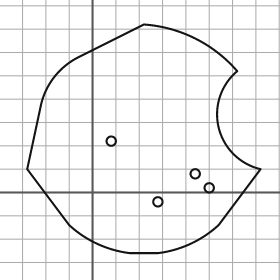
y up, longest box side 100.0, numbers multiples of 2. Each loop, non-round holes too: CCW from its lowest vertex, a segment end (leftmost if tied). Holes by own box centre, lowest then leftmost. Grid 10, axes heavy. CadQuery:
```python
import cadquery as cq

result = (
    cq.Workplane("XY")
    .moveTo(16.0, -26.0)
    .lineTo(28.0, -26.0)
    .threePointArc((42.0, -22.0), (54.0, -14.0))
    .lineTo(72.0, 10.0)
    .threePointArc((54.0, 28.0), (62.0, 52.0))
    .threePointArc((44.0, 66.0), (22.0, 72.0))
    .lineTo(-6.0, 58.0)
    .threePointArc((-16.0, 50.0), (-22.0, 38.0))
    .lineTo(-28.0, 10.0)
    .lineTo(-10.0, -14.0)
    .threePointArc((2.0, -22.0), (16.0, -26.0))
    .close()
    .moveTo(28.0, -4.0)
    .circle(2.0)
    .moveTo(50.0, 2.0)
    .circle(2.0)
    .moveTo(44.0, 8.0)
    .circle(2.0)
    .moveTo(8.0, 22.0)
    .circle(2.0)
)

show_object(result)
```